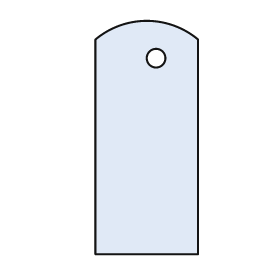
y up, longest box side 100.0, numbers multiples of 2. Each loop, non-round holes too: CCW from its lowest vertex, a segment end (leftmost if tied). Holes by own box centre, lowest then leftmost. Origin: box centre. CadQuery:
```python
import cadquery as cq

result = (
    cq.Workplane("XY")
    .moveTo(-22.0, -50.0)
    .lineTo(22.0, -50.0)
    .lineTo(22.0, 42.0)
    .threePointArc((0.0, 50.0), (-22.0, 42.0))
    .close()
    .moveTo(4.0, 34.0)
    .circle(4.0)
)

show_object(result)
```